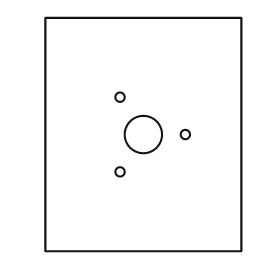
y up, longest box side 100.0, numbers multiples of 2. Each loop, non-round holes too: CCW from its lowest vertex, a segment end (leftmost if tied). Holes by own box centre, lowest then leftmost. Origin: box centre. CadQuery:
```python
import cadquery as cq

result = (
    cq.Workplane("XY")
    .moveTo(-42.0, -50.0)
    .lineTo(42.0, -50.0)
    .lineTo(42.0, 50.0)
    .lineTo(-42.0, 50.0)
    .close()
    .moveTo(-10.0, -16.0)
    .circle(2.0)
    .moveTo(0.0, 0.0)
    .circle(8.0)
    .moveTo(18.0, 0.0)
    .circle(2.0)
    .moveTo(-10.0, 16.0)
    .circle(2.0)
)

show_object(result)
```